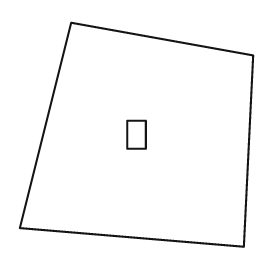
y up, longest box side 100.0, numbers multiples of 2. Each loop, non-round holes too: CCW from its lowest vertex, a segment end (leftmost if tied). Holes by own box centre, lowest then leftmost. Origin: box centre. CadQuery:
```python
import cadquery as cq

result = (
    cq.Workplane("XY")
    .moveTo(46.0, -48.0)
    .lineTo(50.0, 34.0)
    .lineTo(-28.0, 48.0)
    .lineTo(-50.0, -40.0)
    .close()
    .moveTo(-4.0, -6.0)
    .lineTo(4.0, -6.0)
    .lineTo(4.0, 6.0)
    .lineTo(-4.0, 6.0)
    .close()
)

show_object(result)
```